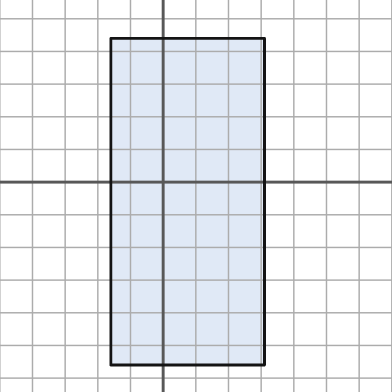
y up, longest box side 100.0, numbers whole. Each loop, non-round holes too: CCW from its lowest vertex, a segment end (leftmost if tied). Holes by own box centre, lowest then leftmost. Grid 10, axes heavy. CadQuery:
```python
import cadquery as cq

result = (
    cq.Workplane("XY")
    .moveTo(-16.0, -56.0)
    .lineTo(31.0, -56.0)
    .lineTo(31.0, 44.0)
    .lineTo(-16.0, 44.0)
    .close()
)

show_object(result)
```